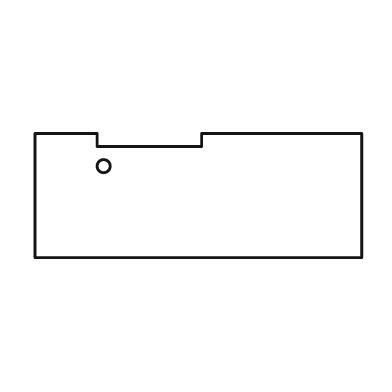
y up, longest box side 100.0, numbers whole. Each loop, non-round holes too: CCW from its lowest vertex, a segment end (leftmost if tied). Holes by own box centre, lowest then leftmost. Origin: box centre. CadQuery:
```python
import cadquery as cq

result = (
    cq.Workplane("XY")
    .moveTo(-50.0, -19.0)
    .lineTo(50.0, -19.0)
    .lineTo(50.0, 19.0)
    .lineTo(1.0, 19.0)
    .lineTo(1.0, 15.0)
    .lineTo(-31.0, 15.0)
    .lineTo(-31.0, 19.0)
    .lineTo(-50.0, 19.0)
    .close()
    .moveTo(-29.0, 9.0)
    .circle(2.0)
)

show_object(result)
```